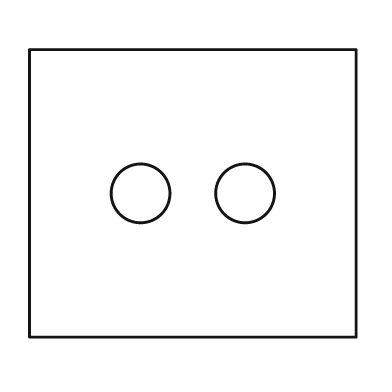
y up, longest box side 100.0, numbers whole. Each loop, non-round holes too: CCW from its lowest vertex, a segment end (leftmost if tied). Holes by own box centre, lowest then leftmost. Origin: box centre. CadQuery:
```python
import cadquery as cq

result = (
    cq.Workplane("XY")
    .moveTo(-50.0, -44.0)
    .lineTo(50.0, -44.0)
    .lineTo(50.0, 44.0)
    .lineTo(-50.0, 44.0)
    .close()
    .moveTo(-16.0, 0.0)
    .circle(9.0)
    .moveTo(16.0, 0.0)
    .circle(9.0)
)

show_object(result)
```